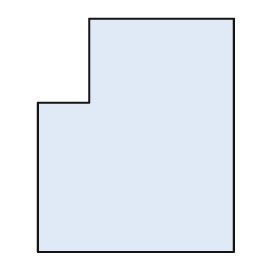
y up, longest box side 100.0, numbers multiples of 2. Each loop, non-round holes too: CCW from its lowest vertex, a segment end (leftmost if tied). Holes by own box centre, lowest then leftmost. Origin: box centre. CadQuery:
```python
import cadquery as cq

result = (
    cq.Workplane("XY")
    .moveTo(-42.0, -50.0)
    .lineTo(42.0, -50.0)
    .lineTo(42.0, 50.0)
    .lineTo(-20.0, 50.0)
    .lineTo(-20.0, 14.0)
    .lineTo(-42.0, 14.0)
    .close()
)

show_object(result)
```